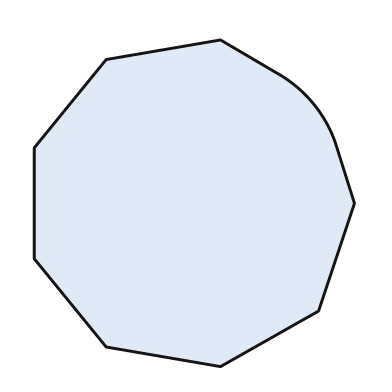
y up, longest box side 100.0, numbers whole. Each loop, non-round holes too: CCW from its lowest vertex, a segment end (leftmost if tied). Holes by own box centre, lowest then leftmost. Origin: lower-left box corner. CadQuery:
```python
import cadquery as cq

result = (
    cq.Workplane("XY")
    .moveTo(57.0, 0.0)
    .lineTo(87.0, 17.0)
    .lineTo(98.0, 50.0)
    .lineTo(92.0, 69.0)
    .threePointArc((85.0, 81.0), (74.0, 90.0))
    .lineTo(57.0, 100.0)
    .lineTo(22.0, 94.0)
    .lineTo(0.0, 67.0)
    .lineTo(0.0, 33.0)
    .lineTo(22.0, 6.0)
    .close()
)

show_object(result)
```